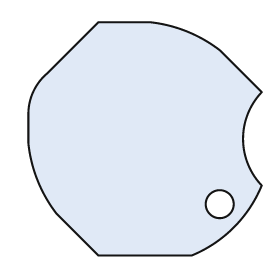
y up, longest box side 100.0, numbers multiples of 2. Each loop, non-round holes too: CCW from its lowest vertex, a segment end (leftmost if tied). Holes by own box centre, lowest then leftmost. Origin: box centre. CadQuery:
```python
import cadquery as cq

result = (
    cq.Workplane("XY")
    .moveTo(-20.0, -50.0)
    .lineTo(20.0, -50.0)
    .threePointArc((38.0, -38.0), (50.0, -20.0))
    .threePointArc((42.0, 0.0), (50.0, 20.0))
    .lineTo(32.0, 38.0)
    .threePointArc((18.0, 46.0), (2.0, 50.0))
    .lineTo(-20.0, 50.0)
    .lineTo(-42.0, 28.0)
    .threePointArc((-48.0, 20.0), (-50.0, 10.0))
    .lineTo(-50.0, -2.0)
    .threePointArc((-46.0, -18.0), (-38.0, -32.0))
    .close()
    .moveTo(32.0, -28.0)
    .circle(6.0)
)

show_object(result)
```